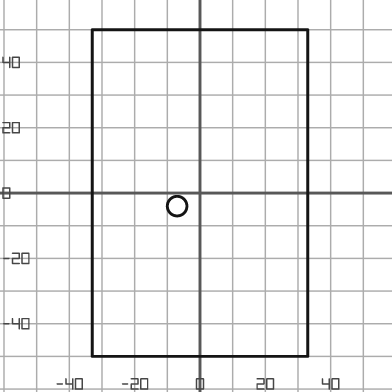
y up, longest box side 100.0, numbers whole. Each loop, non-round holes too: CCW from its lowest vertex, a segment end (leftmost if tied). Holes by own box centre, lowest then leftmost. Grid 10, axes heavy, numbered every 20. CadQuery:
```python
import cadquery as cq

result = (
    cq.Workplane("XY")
    .moveTo(-33.0, -50.0)
    .lineTo(33.0, -50.0)
    .lineTo(33.0, 50.0)
    .lineTo(-33.0, 50.0)
    .close()
    .moveTo(-7.0, -4.0)
    .circle(3.0)
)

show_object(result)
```